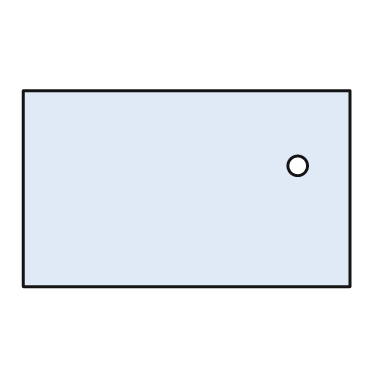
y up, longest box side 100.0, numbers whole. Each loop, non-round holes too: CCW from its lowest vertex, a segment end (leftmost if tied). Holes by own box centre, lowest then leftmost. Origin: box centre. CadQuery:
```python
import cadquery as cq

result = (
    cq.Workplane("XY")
    .moveTo(-50.0, -30.0)
    .lineTo(50.0, -30.0)
    .lineTo(50.0, 30.0)
    .lineTo(-50.0, 30.0)
    .close()
    .moveTo(34.0, 7.0)
    .circle(3.0)
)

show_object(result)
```